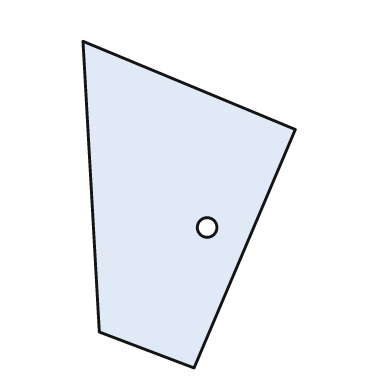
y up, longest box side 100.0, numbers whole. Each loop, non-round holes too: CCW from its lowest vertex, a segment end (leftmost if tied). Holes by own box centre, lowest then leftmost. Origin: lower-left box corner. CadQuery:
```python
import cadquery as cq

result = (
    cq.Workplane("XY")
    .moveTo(34.0, 0.0)
    .lineTo(65.0, 73.0)
    .lineTo(0.0, 100.0)
    .lineTo(5.0, 11.0)
    .close()
    .moveTo(38.0, 43.0)
    .circle(3.0)
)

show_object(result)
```